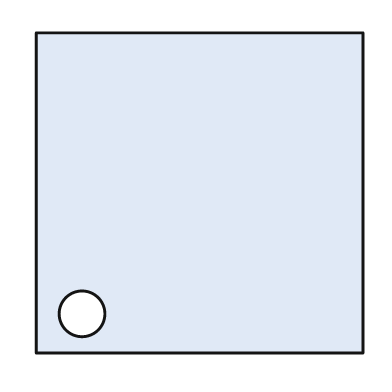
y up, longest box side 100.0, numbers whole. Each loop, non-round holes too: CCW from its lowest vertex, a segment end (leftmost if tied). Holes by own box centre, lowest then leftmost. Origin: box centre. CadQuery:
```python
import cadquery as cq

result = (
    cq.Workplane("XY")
    .moveTo(-50.0, -49.0)
    .lineTo(50.0, -49.0)
    .lineTo(50.0, 49.0)
    .lineTo(-50.0, 49.0)
    .close()
    .moveTo(-36.0, -37.0)
    .circle(7.0)
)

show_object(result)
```